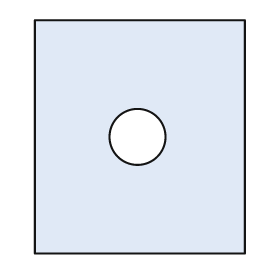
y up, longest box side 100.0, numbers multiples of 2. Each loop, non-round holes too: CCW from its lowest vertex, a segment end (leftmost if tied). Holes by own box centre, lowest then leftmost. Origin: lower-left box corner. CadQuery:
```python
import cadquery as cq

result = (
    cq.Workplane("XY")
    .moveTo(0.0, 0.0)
    .lineTo(90.0, 0.0)
    .lineTo(90.0, 100.0)
    .lineTo(0.0, 100.0)
    .close()
    .moveTo(44.0, 50.0)
    .circle(12.0)
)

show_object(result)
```